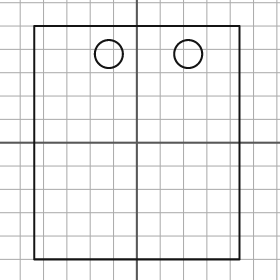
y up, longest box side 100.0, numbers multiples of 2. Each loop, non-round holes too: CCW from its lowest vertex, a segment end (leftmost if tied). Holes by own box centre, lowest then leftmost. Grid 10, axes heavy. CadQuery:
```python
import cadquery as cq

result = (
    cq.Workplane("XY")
    .moveTo(-44.0, -50.0)
    .lineTo(44.0, -50.0)
    .lineTo(44.0, 50.0)
    .lineTo(-44.0, 50.0)
    .close()
    .moveTo(-12.0, 38.0)
    .circle(6.0)
    .moveTo(22.0, 38.0)
    .circle(6.0)
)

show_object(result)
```